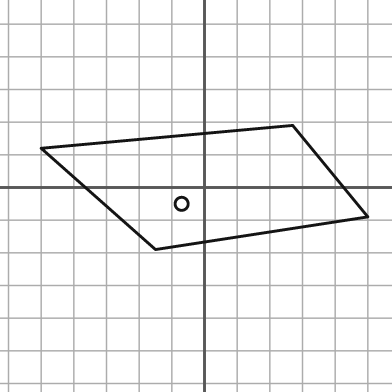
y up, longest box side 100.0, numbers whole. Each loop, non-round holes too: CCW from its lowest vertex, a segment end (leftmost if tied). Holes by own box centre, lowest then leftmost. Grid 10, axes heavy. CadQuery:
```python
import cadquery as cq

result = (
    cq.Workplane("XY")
    .moveTo(-15.0, -19.0)
    .lineTo(50.0, -9.0)
    .lineTo(27.0, 19.0)
    .lineTo(-50.0, 12.0)
    .close()
    .moveTo(-7.0, -5.0)
    .circle(2.0)
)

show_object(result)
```